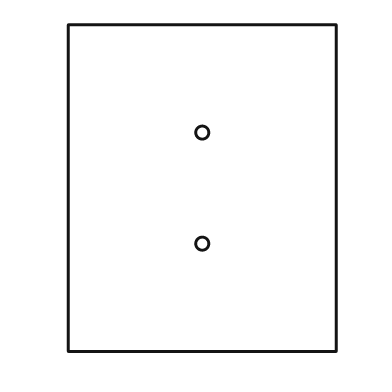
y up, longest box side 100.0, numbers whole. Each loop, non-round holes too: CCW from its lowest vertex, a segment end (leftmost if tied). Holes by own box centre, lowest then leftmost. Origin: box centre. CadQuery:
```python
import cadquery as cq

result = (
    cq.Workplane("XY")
    .moveTo(-41.0, -50.0)
    .lineTo(41.0, -50.0)
    .lineTo(41.0, 50.0)
    .lineTo(-41.0, 50.0)
    .close()
    .moveTo(0.0, -17.0)
    .circle(2.0)
    .moveTo(0.0, 17.0)
    .circle(2.0)
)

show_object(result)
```